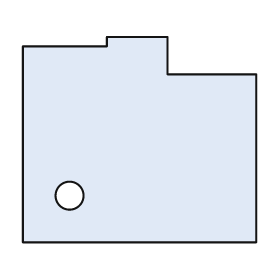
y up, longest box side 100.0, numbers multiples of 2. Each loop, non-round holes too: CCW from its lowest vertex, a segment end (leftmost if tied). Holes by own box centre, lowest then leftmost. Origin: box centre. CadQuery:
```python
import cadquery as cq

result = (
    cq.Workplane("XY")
    .moveTo(-50.0, -44.0)
    .lineTo(50.0, -44.0)
    .lineTo(50.0, 28.0)
    .lineTo(12.0, 28.0)
    .lineTo(12.0, 44.0)
    .lineTo(-14.0, 44.0)
    .lineTo(-14.0, 40.0)
    .lineTo(-50.0, 40.0)
    .close()
    .moveTo(-30.0, -24.0)
    .circle(6.0)
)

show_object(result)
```